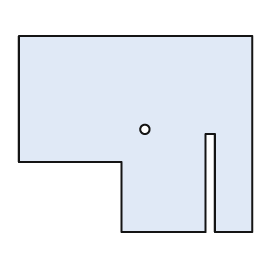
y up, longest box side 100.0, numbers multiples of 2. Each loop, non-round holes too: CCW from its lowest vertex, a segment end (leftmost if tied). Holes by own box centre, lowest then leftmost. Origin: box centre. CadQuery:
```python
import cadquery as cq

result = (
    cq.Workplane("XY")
    .moveTo(-6.0, -42.0)
    .lineTo(30.0, -42.0)
    .lineTo(30.0, 0.0)
    .lineTo(34.0, 0.0)
    .lineTo(34.0, -42.0)
    .lineTo(50.0, -42.0)
    .lineTo(50.0, 42.0)
    .lineTo(-50.0, 42.0)
    .lineTo(-50.0, -12.0)
    .lineTo(-6.0, -12.0)
    .close()
    .moveTo(4.0, 2.0)
    .circle(2.0)
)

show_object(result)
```